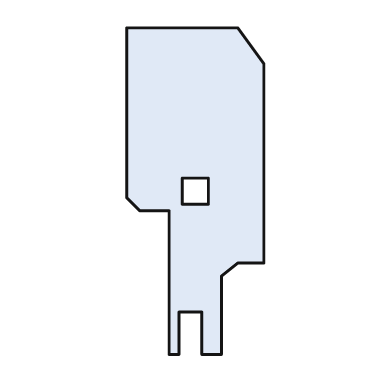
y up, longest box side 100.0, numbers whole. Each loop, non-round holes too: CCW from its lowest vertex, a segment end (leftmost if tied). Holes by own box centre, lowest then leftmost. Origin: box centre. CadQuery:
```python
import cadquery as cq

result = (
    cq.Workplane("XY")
    .moveTo(-8.0, -50.0)
    .lineTo(-5.0, -50.0)
    .lineTo(-5.0, -37.0)
    .lineTo(2.0, -37.0)
    .lineTo(2.0, -50.0)
    .lineTo(8.0, -50.0)
    .lineTo(8.0, -26.0)
    .lineTo(13.0, -22.0)
    .lineTo(21.0, -22.0)
    .lineTo(21.0, 39.0)
    .lineTo(13.0, 50.0)
    .lineTo(-21.0, 50.0)
    .lineTo(-21.0, -2.0)
    .lineTo(-17.0, -6.0)
    .lineTo(-8.0, -6.0)
    .close()
    .moveTo(-4.0, -4.0)
    .lineTo(4.0, -4.0)
    .lineTo(4.0, 4.0)
    .lineTo(-4.0, 4.0)
    .close()
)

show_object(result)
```